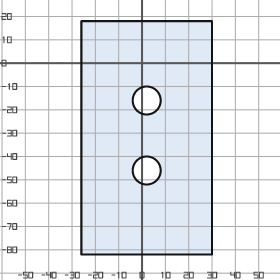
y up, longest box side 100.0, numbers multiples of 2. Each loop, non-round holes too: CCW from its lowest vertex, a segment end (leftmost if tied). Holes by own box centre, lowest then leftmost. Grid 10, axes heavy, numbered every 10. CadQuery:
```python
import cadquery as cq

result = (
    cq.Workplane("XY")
    .moveTo(-26.0, -82.0)
    .lineTo(30.0, -82.0)
    .lineTo(30.0, 18.0)
    .lineTo(-26.0, 18.0)
    .close()
    .moveTo(2.0, -46.0)
    .circle(6.0)
    .moveTo(2.0, -16.0)
    .circle(6.0)
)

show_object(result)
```